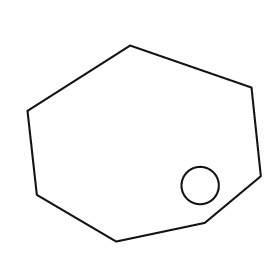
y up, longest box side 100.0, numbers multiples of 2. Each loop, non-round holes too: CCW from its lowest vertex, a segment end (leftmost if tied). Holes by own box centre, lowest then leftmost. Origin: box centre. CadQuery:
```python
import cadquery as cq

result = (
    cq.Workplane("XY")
    .moveTo(-12.0, -42.0)
    .lineTo(26.0, -34.0)
    .lineTo(50.0, -14.0)
    .lineTo(46.0, 24.0)
    .lineTo(-6.0, 42.0)
    .lineTo(-50.0, 14.0)
    .lineTo(-46.0, -22.0)
    .close()
    .moveTo(24.0, -18.0)
    .circle(8.0)
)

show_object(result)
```